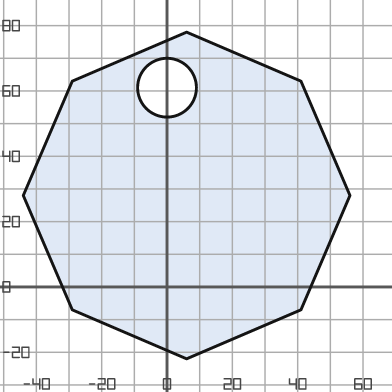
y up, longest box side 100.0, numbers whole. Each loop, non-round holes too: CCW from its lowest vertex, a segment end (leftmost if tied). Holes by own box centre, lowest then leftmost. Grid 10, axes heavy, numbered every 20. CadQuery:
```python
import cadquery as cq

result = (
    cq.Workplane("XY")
    .moveTo(6.0, -22.0)
    .lineTo(41.0, -7.0)
    .lineTo(56.0, 28.0)
    .lineTo(41.0, 63.0)
    .lineTo(6.0, 78.0)
    .lineTo(-29.0, 63.0)
    .lineTo(-44.0, 28.0)
    .lineTo(-29.0, -7.0)
    .close()
    .moveTo(0.0, 61.0)
    .circle(9.0)
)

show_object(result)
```